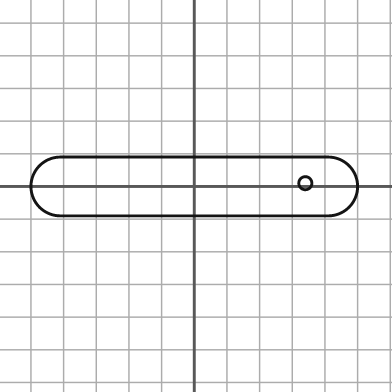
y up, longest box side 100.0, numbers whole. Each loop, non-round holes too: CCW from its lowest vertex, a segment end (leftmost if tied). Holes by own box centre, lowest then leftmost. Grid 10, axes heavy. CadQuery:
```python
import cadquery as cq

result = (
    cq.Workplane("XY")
    .moveTo(-41.0, -9.0)
    .lineTo(41.0, -9.0)
    .threePointArc((50.0, 0.0), (41.0, 9.0))
    .lineTo(-41.0, 9.0)
    .threePointArc((-50.0, 0.0), (-41.0, -9.0))
    .close()
    .moveTo(34.0, 1.0)
    .circle(2.0)
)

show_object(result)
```